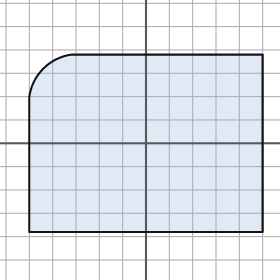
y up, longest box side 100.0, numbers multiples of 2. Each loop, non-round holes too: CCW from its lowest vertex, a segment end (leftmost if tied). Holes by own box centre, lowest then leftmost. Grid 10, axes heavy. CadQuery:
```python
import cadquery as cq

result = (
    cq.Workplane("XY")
    .moveTo(-50.0, -38.0)
    .lineTo(50.0, -38.0)
    .lineTo(50.0, 38.0)
    .lineTo(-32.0, 38.0)
    .threePointArc((-44.0, 32.0), (-50.0, 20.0))
    .close()
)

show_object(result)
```